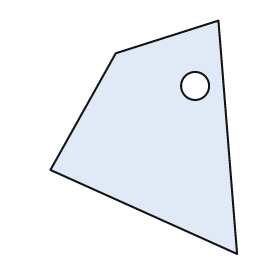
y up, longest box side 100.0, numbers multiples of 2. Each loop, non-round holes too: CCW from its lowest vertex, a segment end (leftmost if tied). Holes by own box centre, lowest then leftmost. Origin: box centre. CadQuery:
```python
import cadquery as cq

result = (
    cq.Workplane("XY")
    .moveTo(40.0, -50.0)
    .lineTo(32.0, 50.0)
    .lineTo(-12.0, 36.0)
    .lineTo(-40.0, -14.0)
    .close()
    .moveTo(22.0, 22.0)
    .circle(6.0)
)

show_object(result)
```